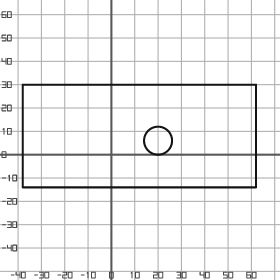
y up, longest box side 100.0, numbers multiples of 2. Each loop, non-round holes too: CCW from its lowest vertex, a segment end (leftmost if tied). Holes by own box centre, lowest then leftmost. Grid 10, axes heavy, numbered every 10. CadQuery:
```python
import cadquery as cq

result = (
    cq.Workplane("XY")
    .moveTo(-38.0, -14.0)
    .lineTo(62.0, -14.0)
    .lineTo(62.0, 30.0)
    .lineTo(-38.0, 30.0)
    .close()
    .moveTo(20.0, 6.0)
    .circle(6.0)
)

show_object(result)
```